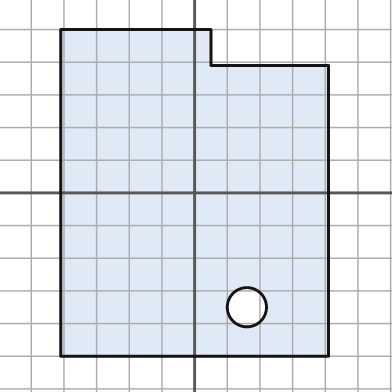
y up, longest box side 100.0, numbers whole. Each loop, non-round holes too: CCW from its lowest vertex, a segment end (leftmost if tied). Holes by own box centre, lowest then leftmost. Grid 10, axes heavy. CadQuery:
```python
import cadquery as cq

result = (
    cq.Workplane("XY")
    .moveTo(-41.0, -50.0)
    .lineTo(41.0, -50.0)
    .lineTo(41.0, 39.0)
    .lineTo(5.0, 39.0)
    .lineTo(5.0, 50.0)
    .lineTo(-41.0, 50.0)
    .close()
    .moveTo(16.0, -35.0)
    .circle(6.0)
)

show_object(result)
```